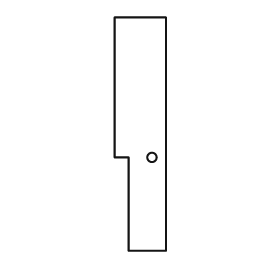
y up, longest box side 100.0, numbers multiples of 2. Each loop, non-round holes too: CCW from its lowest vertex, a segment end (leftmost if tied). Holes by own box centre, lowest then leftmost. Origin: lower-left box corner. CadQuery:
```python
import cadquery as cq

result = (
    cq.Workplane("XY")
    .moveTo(6.0, 0.0)
    .lineTo(22.0, 0.0)
    .lineTo(22.0, 100.0)
    .lineTo(0.0, 100.0)
    .lineTo(0.0, 40.0)
    .lineTo(6.0, 40.0)
    .close()
    .moveTo(16.0, 40.0)
    .circle(2.0)
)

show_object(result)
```